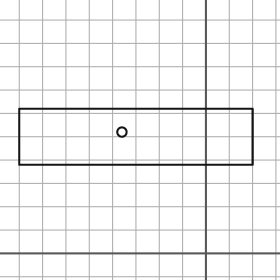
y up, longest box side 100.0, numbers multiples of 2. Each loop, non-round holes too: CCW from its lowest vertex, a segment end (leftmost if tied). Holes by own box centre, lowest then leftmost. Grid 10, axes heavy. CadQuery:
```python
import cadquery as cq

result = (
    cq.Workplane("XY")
    .moveTo(-80.0, 38.0)
    .lineTo(20.0, 38.0)
    .lineTo(20.0, 62.0)
    .lineTo(-80.0, 62.0)
    .close()
    .moveTo(-36.0, 52.0)
    .circle(2.0)
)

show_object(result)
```